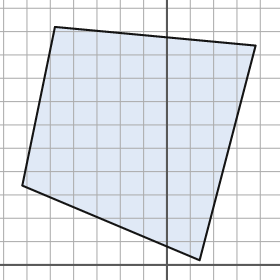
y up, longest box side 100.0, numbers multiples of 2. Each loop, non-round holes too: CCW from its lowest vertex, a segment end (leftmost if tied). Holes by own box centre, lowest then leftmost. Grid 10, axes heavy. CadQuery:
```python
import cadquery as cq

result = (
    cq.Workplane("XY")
    .moveTo(14.0, 2.0)
    .lineTo(38.0, 94.0)
    .lineTo(-48.0, 102.0)
    .lineTo(-62.0, 34.0)
    .close()
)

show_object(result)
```